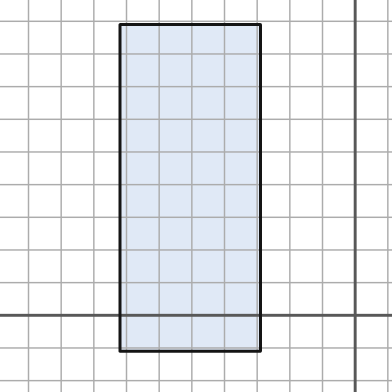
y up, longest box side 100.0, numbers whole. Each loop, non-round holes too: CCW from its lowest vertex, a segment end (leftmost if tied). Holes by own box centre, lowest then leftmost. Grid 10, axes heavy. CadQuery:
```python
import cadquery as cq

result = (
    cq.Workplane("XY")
    .moveTo(-72.0, -11.0)
    .lineTo(-29.0, -11.0)
    .lineTo(-29.0, 89.0)
    .lineTo(-72.0, 89.0)
    .close()
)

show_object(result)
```